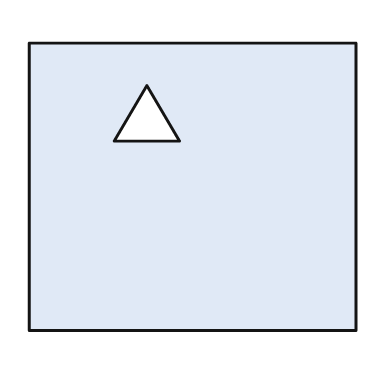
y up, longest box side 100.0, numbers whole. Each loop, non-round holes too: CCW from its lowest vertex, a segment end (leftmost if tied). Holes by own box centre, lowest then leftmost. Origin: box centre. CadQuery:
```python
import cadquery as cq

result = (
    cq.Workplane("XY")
    .moveTo(-50.0, -44.0)
    .lineTo(50.0, -44.0)
    .lineTo(50.0, 44.0)
    .lineTo(-50.0, 44.0)
    .close()
    .moveTo(-24.0, 14.0)
    .lineTo(-4.0, 14.0)
    .lineTo(-14.0, 31.0)
    .close()
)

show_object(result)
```